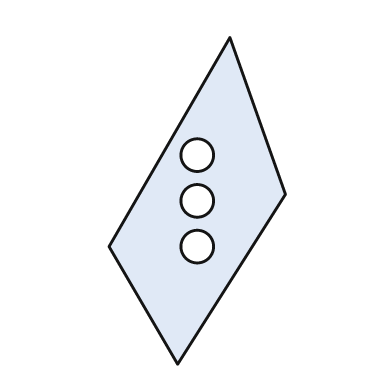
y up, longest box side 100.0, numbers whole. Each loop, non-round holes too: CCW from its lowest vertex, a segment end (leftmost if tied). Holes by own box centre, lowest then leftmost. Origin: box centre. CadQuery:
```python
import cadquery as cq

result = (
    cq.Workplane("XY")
    .moveTo(-6.0, -50.0)
    .lineTo(27.0, 2.0)
    .lineTo(10.0, 50.0)
    .lineTo(-27.0, -14.0)
    .close()
    .moveTo(0.0, -14.0)
    .circle(5.0)
    .moveTo(0.0, 0.0)
    .circle(5.0)
    .moveTo(0.0, 14.0)
    .circle(5.0)
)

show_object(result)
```